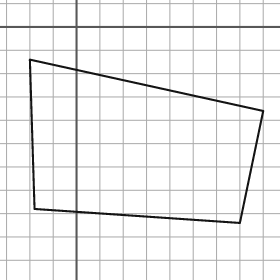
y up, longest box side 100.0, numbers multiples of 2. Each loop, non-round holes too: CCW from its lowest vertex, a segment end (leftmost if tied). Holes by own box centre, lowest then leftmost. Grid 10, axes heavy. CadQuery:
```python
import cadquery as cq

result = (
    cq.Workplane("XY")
    .moveTo(70.0, -84.0)
    .lineTo(80.0, -36.0)
    .lineTo(-20.0, -14.0)
    .lineTo(-18.0, -78.0)
    .close()
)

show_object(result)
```